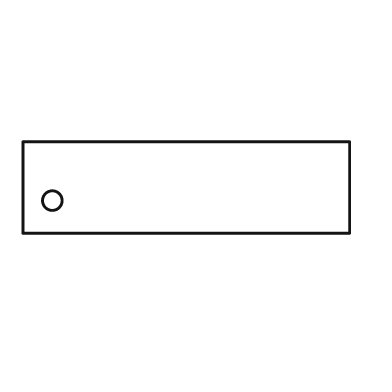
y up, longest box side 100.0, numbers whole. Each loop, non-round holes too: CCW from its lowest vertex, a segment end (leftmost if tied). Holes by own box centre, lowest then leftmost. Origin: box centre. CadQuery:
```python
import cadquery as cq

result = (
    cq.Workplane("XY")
    .moveTo(-50.0, -14.0)
    .lineTo(50.0, -14.0)
    .lineTo(50.0, 14.0)
    .lineTo(-50.0, 14.0)
    .close()
    .moveTo(-41.0, -4.0)
    .circle(3.0)
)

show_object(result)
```